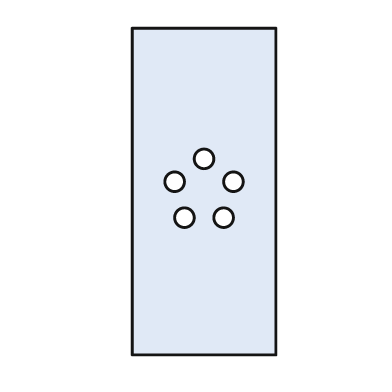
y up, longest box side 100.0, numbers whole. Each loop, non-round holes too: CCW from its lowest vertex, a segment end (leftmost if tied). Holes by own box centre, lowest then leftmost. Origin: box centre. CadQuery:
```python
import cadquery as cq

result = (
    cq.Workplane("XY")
    .moveTo(-22.0, -50.0)
    .lineTo(22.0, -50.0)
    .lineTo(22.0, 50.0)
    .lineTo(-22.0, 50.0)
    .close()
    .moveTo(-6.0, -8.0)
    .circle(3.0)
    .moveTo(6.0, -8.0)
    .circle(3.0)
    .moveTo(-9.0, 3.0)
    .circle(3.0)
    .moveTo(9.0, 3.0)
    .circle(3.0)
    .moveTo(0.0, 10.0)
    .circle(3.0)
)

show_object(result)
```